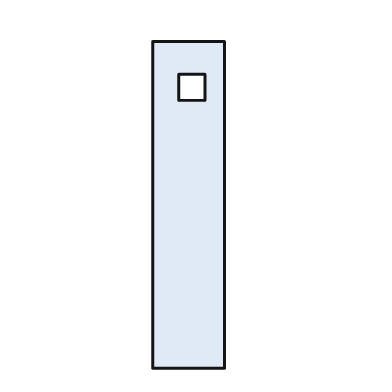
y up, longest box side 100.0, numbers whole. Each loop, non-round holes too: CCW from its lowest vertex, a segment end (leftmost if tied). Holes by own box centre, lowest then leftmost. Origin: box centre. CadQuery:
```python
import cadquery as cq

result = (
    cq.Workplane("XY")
    .moveTo(-11.0, -50.0)
    .lineTo(11.0, -50.0)
    .lineTo(11.0, 50.0)
    .lineTo(-11.0, 50.0)
    .close()
    .moveTo(-3.0, 32.0)
    .lineTo(5.0, 32.0)
    .lineTo(5.0, 40.0)
    .lineTo(-3.0, 40.0)
    .close()
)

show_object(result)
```